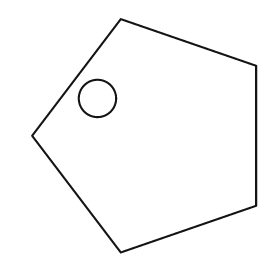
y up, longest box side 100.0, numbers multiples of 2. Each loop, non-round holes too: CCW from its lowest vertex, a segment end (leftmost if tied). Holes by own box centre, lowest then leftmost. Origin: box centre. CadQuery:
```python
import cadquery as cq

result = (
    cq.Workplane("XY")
    .moveTo(-10.0, -50.0)
    .lineTo(48.0, -30.0)
    .lineTo(48.0, 30.0)
    .lineTo(-10.0, 50.0)
    .lineTo(-48.0, 0.0)
    .close()
    .moveTo(-20.0, 16.0)
    .circle(8.0)
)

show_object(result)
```